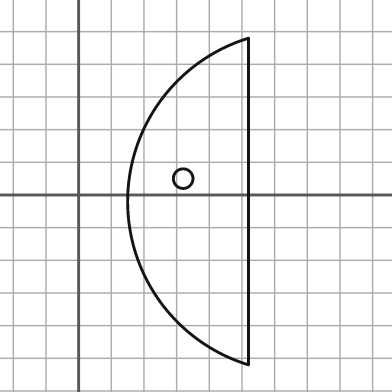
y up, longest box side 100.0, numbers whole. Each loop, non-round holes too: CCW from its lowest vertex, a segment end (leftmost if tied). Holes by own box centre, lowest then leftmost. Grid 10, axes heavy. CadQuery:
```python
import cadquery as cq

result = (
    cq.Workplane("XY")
    .moveTo(52.0, -52.0)
    .lineTo(52.0, 48.0)
    .threePointArc((15.0, -2.0), (52.0, -52.0))
    .close()
    .moveTo(32.0, 5.0)
    .circle(3.0)
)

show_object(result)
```